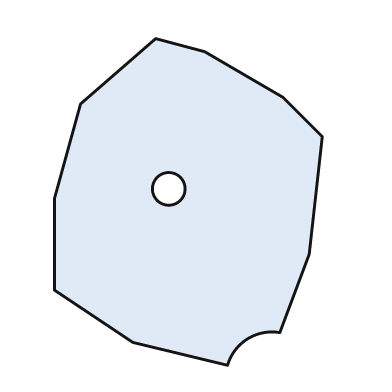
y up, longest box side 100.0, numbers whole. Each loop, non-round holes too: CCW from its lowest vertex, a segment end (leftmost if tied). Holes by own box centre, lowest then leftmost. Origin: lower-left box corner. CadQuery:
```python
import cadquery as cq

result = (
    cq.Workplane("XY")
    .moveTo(53.0, 0.0)
    .threePointArc((59.0, 8.0), (69.0, 10.0))
    .lineTo(78.0, 34.0)
    .lineTo(82.0, 70.0)
    .lineTo(70.0, 82.0)
    .lineTo(46.0, 96.0)
    .lineTo(31.0, 100.0)
    .lineTo(8.0, 80.0)
    .lineTo(0.0, 51.0)
    .lineTo(0.0, 23.0)
    .lineTo(24.0, 7.0)
    .close()
    .moveTo(35.0, 54.0)
    .circle(5.0)
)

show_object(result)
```